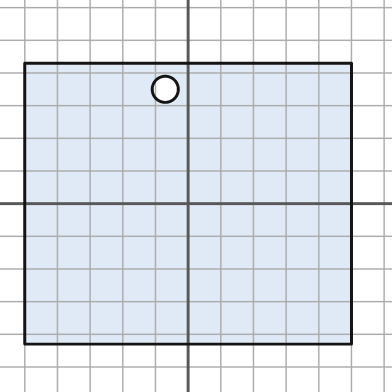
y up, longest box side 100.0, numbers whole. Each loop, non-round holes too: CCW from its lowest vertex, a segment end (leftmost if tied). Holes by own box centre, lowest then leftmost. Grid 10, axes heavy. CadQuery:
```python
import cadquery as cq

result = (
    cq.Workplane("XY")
    .moveTo(-50.0, -43.0)
    .lineTo(50.0, -43.0)
    .lineTo(50.0, 43.0)
    .lineTo(-50.0, 43.0)
    .close()
    .moveTo(-7.0, 35.0)
    .circle(4.0)
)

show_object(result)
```